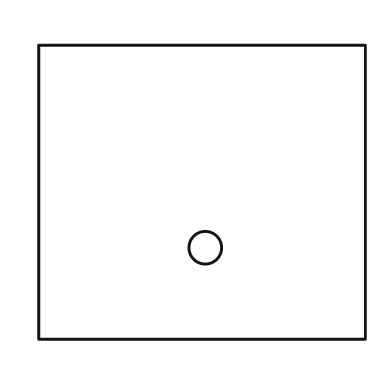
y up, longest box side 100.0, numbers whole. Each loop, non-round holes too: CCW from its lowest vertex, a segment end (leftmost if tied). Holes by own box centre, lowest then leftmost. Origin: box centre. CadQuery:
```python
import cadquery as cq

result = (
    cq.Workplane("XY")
    .moveTo(-50.0, -45.0)
    .lineTo(50.0, -45.0)
    .lineTo(50.0, 45.0)
    .lineTo(-50.0, 45.0)
    .close()
    .moveTo(1.0, -17.0)
    .circle(5.0)
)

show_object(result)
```